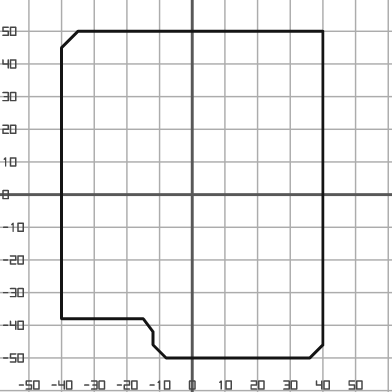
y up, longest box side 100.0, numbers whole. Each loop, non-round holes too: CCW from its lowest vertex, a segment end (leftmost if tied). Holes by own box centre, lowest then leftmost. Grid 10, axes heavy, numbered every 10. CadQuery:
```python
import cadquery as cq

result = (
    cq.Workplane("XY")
    .moveTo(-8.0, -50.0)
    .lineTo(36.0, -50.0)
    .lineTo(40.0, -46.0)
    .lineTo(40.0, 50.0)
    .lineTo(-35.0, 50.0)
    .lineTo(-40.0, 45.0)
    .lineTo(-40.0, -38.0)
    .lineTo(-15.0, -38.0)
    .lineTo(-12.0, -42.0)
    .lineTo(-12.0, -46.0)
    .close()
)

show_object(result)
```